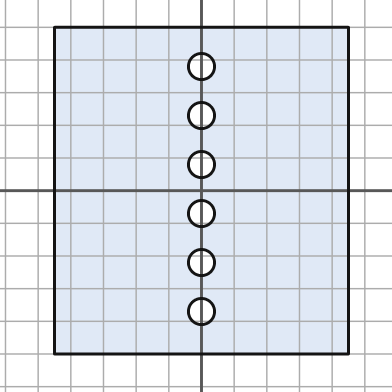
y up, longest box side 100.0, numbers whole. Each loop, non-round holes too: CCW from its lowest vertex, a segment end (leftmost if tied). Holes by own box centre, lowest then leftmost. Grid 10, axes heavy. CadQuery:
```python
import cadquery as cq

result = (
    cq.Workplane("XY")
    .moveTo(-45.0, -50.0)
    .lineTo(45.0, -50.0)
    .lineTo(45.0, 50.0)
    .lineTo(-45.0, 50.0)
    .close()
    .moveTo(0.0, -37.0)
    .circle(4.0)
    .moveTo(0.0, -22.0)
    .circle(4.0)
    .moveTo(0.0, -7.0)
    .circle(4.0)
    .moveTo(0.0, 8.0)
    .circle(4.0)
    .moveTo(0.0, 23.0)
    .circle(4.0)
    .moveTo(0.0, 38.0)
    .circle(4.0)
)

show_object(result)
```